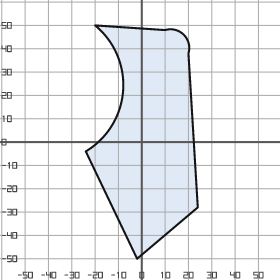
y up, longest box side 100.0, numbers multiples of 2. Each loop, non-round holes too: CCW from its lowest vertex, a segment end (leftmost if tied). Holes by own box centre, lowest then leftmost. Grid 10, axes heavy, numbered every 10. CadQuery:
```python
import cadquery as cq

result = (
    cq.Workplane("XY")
    .moveTo(-2.0, -50.0)
    .lineTo(24.0, -28.0)
    .lineTo(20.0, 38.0)
    .threePointArc((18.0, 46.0), (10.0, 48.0))
    .lineTo(-20.0, 50.0)
    .threePointArc((-8.0, 22.0), (-24.0, -4.0))
    .close()
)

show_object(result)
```